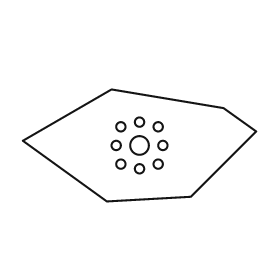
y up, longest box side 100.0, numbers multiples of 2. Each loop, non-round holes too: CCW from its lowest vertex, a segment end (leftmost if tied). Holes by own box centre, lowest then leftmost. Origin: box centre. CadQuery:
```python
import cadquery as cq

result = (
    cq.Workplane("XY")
    .moveTo(-14.0, -24.0)
    .lineTo(22.0, -22.0)
    .lineTo(50.0, 6.0)
    .lineTo(36.0, 16.0)
    .lineTo(-12.0, 24.0)
    .lineTo(-50.0, 2.0)
    .close()
    .moveTo(0.0, -10.0)
    .circle(2.0)
    .moveTo(-8.0, -8.0)
    .circle(2.0)
    .moveTo(8.0, -8.0)
    .circle(2.0)
    .moveTo(-10.0, 0.0)
    .circle(2.0)
    .moveTo(0.0, 0.0)
    .circle(4.0)
    .moveTo(10.0, 0.0)
    .circle(2.0)
    .moveTo(-8.0, 8.0)
    .circle(2.0)
    .moveTo(8.0, 8.0)
    .circle(2.0)
    .moveTo(0.0, 10.0)
    .circle(2.0)
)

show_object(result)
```